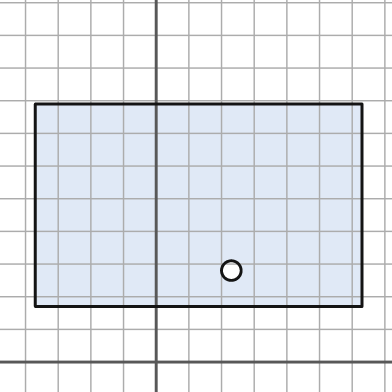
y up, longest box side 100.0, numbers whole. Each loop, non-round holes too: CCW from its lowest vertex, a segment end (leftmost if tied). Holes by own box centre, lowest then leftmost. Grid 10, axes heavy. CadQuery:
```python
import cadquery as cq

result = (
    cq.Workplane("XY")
    .moveTo(-37.0, 17.0)
    .lineTo(63.0, 17.0)
    .lineTo(63.0, 79.0)
    .lineTo(-37.0, 79.0)
    .close()
    .moveTo(23.0, 28.0)
    .circle(3.0)
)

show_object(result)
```